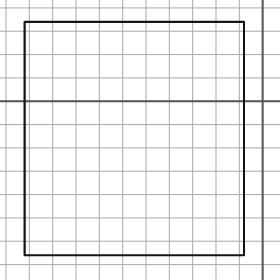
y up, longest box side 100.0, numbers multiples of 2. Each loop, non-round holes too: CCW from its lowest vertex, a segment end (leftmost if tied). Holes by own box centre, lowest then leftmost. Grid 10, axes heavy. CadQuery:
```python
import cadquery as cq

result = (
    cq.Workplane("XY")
    .moveTo(-102.0, -66.0)
    .lineTo(-8.0, -66.0)
    .lineTo(-8.0, 34.0)
    .lineTo(-102.0, 34.0)
    .close()
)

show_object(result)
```